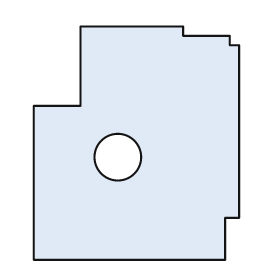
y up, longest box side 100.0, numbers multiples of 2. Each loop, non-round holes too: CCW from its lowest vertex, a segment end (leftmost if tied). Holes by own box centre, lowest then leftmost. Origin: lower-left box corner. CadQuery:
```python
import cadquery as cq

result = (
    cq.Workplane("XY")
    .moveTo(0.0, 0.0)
    .lineTo(82.0, 0.0)
    .lineTo(82.0, 18.0)
    .lineTo(88.0, 18.0)
    .lineTo(88.0, 92.0)
    .lineTo(84.0, 92.0)
    .lineTo(84.0, 96.0)
    .lineTo(64.0, 96.0)
    .lineTo(64.0, 100.0)
    .lineTo(20.0, 100.0)
    .lineTo(20.0, 66.0)
    .lineTo(0.0, 66.0)
    .close()
    .moveTo(36.0, 44.0)
    .circle(10.0)
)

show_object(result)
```